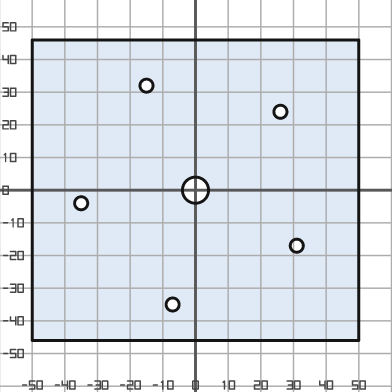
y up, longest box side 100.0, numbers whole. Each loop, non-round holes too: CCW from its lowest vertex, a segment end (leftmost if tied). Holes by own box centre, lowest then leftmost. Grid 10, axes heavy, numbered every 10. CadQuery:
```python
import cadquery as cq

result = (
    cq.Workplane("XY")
    .moveTo(-50.0, -46.0)
    .lineTo(50.0, -46.0)
    .lineTo(50.0, 46.0)
    .lineTo(-50.0, 46.0)
    .close()
    .moveTo(-7.0, -35.0)
    .circle(2.0)
    .moveTo(31.0, -17.0)
    .circle(2.0)
    .moveTo(-35.0, -4.0)
    .circle(2.0)
    .moveTo(0.0, 0.0)
    .circle(4.0)
    .moveTo(26.0, 24.0)
    .circle(2.0)
    .moveTo(-15.0, 32.0)
    .circle(2.0)
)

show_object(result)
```